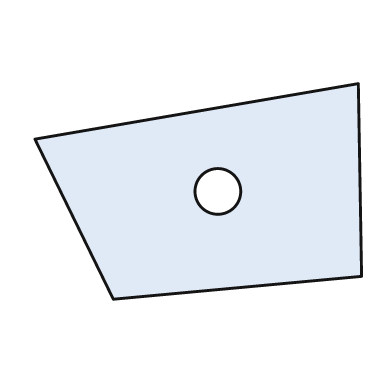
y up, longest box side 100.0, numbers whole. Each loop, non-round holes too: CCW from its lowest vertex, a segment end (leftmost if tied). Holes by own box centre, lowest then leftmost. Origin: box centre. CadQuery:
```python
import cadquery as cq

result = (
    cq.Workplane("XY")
    .moveTo(-26.0, -33.0)
    .lineTo(50.0, -26.0)
    .lineTo(49.0, 33.0)
    .lineTo(-50.0, 16.0)
    .close()
    .moveTo(6.0, 0.0)
    .circle(7.0)
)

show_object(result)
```